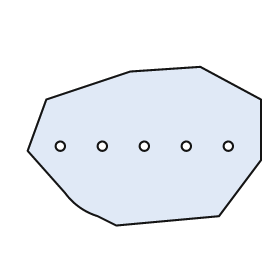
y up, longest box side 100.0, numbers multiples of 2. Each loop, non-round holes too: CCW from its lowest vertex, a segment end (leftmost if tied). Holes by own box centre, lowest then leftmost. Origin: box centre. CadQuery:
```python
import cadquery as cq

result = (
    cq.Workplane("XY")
    .moveTo(-12.0, -34.0)
    .lineTo(32.0, -30.0)
    .lineTo(50.0, -6.0)
    .lineTo(50.0, 20.0)
    .lineTo(24.0, 34.0)
    .lineTo(-6.0, 32.0)
    .lineTo(-42.0, 20.0)
    .lineTo(-50.0, -2.0)
    .lineTo(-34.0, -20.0)
    .threePointArc((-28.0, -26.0), (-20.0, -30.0))
    .close()
    .moveTo(-36.0, 0.0)
    .circle(2.0)
    .moveTo(-18.0, 0.0)
    .circle(2.0)
    .moveTo(0.0, 0.0)
    .circle(2.0)
    .moveTo(18.0, 0.0)
    .circle(2.0)
    .moveTo(36.0, 0.0)
    .circle(2.0)
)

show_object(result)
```